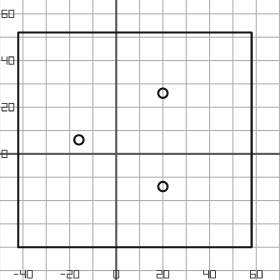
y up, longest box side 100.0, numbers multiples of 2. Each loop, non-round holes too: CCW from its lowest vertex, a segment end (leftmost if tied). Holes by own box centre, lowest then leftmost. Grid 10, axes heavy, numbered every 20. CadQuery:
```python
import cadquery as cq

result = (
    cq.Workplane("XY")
    .moveTo(-42.0, -40.0)
    .lineTo(58.0, -40.0)
    .lineTo(58.0, 52.0)
    .lineTo(-42.0, 52.0)
    .close()
    .moveTo(20.0, -14.0)
    .circle(2.0)
    .moveTo(-16.0, 6.0)
    .circle(2.0)
    .moveTo(20.0, 26.0)
    .circle(2.0)
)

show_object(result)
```